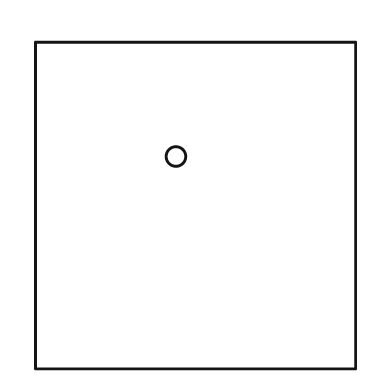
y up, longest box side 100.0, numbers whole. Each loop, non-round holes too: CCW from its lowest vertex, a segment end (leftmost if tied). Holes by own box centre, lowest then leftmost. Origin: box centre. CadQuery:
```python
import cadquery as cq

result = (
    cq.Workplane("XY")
    .moveTo(-49.0, -50.0)
    .lineTo(49.0, -50.0)
    .lineTo(49.0, 50.0)
    .lineTo(-49.0, 50.0)
    .close()
    .moveTo(-6.0, 15.0)
    .circle(3.0)
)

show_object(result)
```